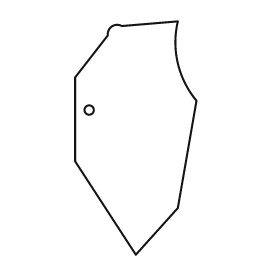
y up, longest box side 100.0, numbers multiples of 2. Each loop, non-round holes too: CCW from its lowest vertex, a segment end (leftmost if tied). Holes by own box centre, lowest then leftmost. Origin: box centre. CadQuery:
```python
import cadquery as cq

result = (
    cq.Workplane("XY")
    .moveTo(0.0, -50.0)
    .lineTo(18.0, -30.0)
    .lineTo(26.0, 16.0)
    .threePointArc((18.0, 32.0), (18.0, 50.0))
    .lineTo(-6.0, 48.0)
    .threePointArc((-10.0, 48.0), (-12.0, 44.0))
    .lineTo(-26.0, 26.0)
    .lineTo(-26.0, -10.0)
    .close()
    .moveTo(-20.0, 12.0)
    .circle(2.0)
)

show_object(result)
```